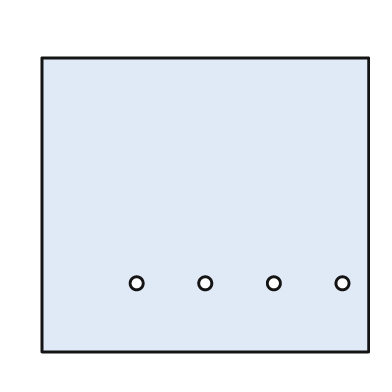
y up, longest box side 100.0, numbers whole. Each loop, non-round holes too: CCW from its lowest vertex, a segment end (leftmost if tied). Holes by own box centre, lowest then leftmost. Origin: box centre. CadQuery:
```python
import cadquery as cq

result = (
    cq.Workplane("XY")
    .moveTo(-50.0, -45.0)
    .lineTo(50.0, -45.0)
    .lineTo(50.0, 45.0)
    .lineTo(-50.0, 45.0)
    .close()
    .moveTo(-21.0, -24.0)
    .circle(2.0)
    .moveTo(0.0, -24.0)
    .circle(2.0)
    .moveTo(21.0, -24.0)
    .circle(2.0)
    .moveTo(42.0, -24.0)
    .circle(2.0)
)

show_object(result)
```